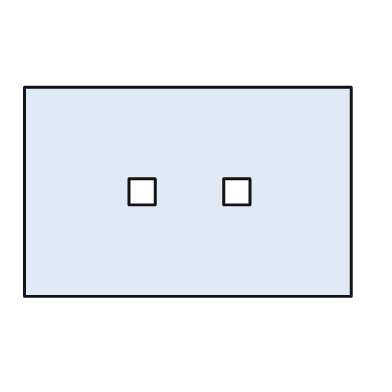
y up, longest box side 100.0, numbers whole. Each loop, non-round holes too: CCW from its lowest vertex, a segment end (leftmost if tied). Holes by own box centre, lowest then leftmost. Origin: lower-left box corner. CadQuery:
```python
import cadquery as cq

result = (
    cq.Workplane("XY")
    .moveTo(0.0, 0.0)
    .lineTo(100.0, 0.0)
    .lineTo(100.0, 64.0)
    .lineTo(0.0, 64.0)
    .close()
    .moveTo(32.0, 28.0)
    .lineTo(40.0, 28.0)
    .lineTo(40.0, 36.0)
    .lineTo(32.0, 36.0)
    .close()
    .moveTo(61.0, 28.0)
    .lineTo(69.0, 28.0)
    .lineTo(69.0, 36.0)
    .lineTo(61.0, 36.0)
    .close()
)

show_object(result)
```